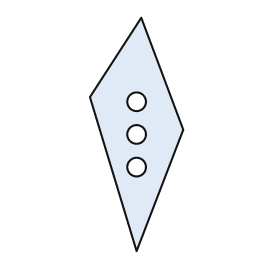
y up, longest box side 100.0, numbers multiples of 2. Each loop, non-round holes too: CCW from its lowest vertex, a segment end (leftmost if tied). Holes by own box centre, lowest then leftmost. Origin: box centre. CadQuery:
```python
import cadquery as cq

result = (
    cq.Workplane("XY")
    .moveTo(0.0, -50.0)
    .lineTo(20.0, 2.0)
    .lineTo(2.0, 50.0)
    .lineTo(-20.0, 16.0)
    .close()
    .moveTo(0.0, -14.0)
    .circle(4.0)
    .moveTo(0.0, 0.0)
    .circle(4.0)
    .moveTo(0.0, 14.0)
    .circle(4.0)
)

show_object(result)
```